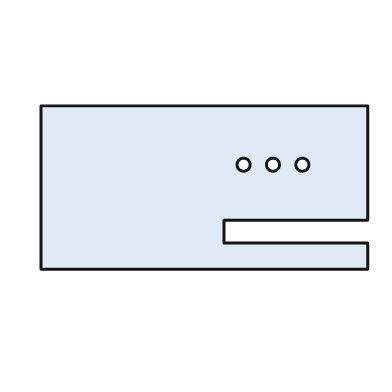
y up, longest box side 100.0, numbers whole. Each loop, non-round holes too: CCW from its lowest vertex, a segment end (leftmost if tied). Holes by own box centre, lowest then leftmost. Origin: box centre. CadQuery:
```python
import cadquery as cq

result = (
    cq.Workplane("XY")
    .moveTo(-50.0, -25.0)
    .lineTo(50.0, -25.0)
    .lineTo(50.0, -17.0)
    .lineTo(6.0, -17.0)
    .lineTo(6.0, -10.0)
    .lineTo(50.0, -10.0)
    .lineTo(50.0, 25.0)
    .lineTo(-50.0, 25.0)
    .close()
    .moveTo(12.0, 7.0)
    .circle(2.0)
    .moveTo(21.0, 7.0)
    .circle(2.0)
    .moveTo(30.0, 7.0)
    .circle(2.0)
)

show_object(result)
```